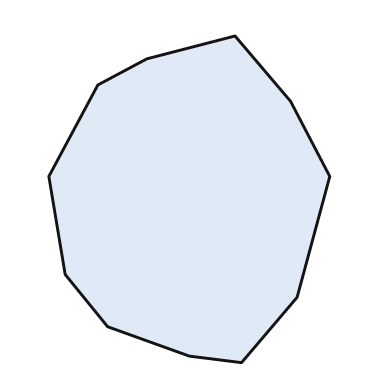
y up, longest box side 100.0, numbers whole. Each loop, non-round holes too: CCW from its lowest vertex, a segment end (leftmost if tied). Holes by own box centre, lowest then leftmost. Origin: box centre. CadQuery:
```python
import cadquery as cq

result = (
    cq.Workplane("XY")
    .moveTo(16.0, -50.0)
    .lineTo(33.0, -30.0)
    .lineTo(43.0, 7.0)
    .lineTo(31.0, 30.0)
    .lineTo(14.0, 50.0)
    .lineTo(-13.0, 43.0)
    .lineTo(-28.0, 35.0)
    .lineTo(-43.0, 7.0)
    .lineTo(-38.0, -23.0)
    .lineTo(-25.0, -39.0)
    .lineTo(0.0, -48.0)
    .close()
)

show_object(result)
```